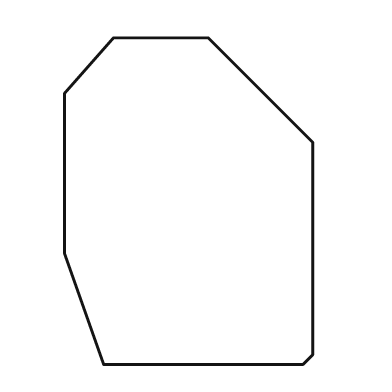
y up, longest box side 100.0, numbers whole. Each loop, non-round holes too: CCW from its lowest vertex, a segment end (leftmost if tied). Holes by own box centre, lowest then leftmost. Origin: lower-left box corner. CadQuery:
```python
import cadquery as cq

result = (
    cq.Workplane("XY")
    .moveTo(12.0, 0.0)
    .lineTo(73.0, 0.0)
    .lineTo(76.0, 3.0)
    .lineTo(76.0, 68.0)
    .lineTo(44.0, 100.0)
    .lineTo(15.0, 100.0)
    .lineTo(0.0, 83.0)
    .lineTo(0.0, 34.0)
    .close()
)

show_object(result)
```